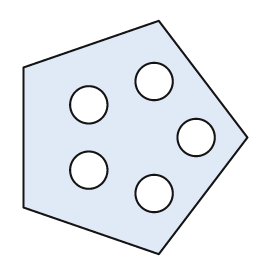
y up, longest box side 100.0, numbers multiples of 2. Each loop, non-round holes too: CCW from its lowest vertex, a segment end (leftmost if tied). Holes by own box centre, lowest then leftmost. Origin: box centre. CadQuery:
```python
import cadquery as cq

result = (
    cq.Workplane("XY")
    .moveTo(10.0, -50.0)
    .lineTo(48.0, 0.0)
    .lineTo(10.0, 50.0)
    .lineTo(-48.0, 30.0)
    .lineTo(-48.0, -30.0)
    .close()
    .moveTo(8.0, -24.0)
    .circle(8.0)
    .moveTo(-20.0, -14.0)
    .circle(8.0)
    .moveTo(26.0, 0.0)
    .circle(8.0)
    .moveTo(-20.0, 14.0)
    .circle(8.0)
    .moveTo(8.0, 24.0)
    .circle(8.0)
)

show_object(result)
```